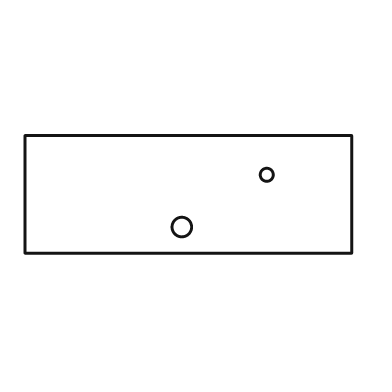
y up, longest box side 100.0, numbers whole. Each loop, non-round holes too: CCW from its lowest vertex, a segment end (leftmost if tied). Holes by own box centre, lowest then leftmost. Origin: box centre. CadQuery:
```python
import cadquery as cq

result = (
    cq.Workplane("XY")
    .moveTo(-50.0, -18.0)
    .lineTo(50.0, -18.0)
    .lineTo(50.0, 18.0)
    .lineTo(-50.0, 18.0)
    .close()
    .moveTo(-2.0, -10.0)
    .circle(3.0)
    .moveTo(24.0, 6.0)
    .circle(2.0)
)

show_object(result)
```